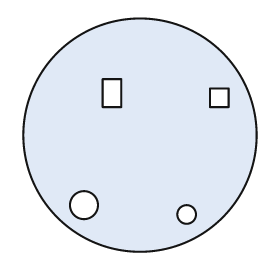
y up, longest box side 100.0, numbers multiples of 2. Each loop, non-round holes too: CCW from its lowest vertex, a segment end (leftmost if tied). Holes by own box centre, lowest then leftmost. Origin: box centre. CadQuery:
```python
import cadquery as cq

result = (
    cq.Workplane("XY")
    .moveTo(0.0, 0.0)
    .circle(50.0)
    .moveTo(20.0, -34.0)
    .circle(4.0)
    .moveTo(-24.0, -30.0)
    .circle(6.0)
    .moveTo(30.0, 12.0)
    .lineTo(38.0, 12.0)
    .lineTo(38.0, 20.0)
    .lineTo(30.0, 20.0)
    .close()
    .moveTo(-16.0, 12.0)
    .lineTo(-8.0, 12.0)
    .lineTo(-8.0, 24.0)
    .lineTo(-16.0, 24.0)
    .close()
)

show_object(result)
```